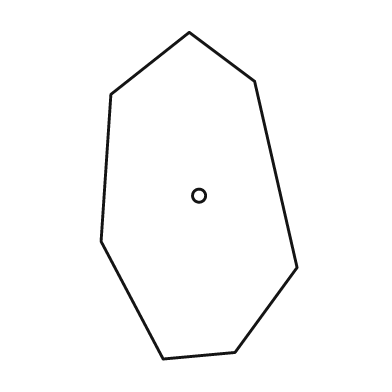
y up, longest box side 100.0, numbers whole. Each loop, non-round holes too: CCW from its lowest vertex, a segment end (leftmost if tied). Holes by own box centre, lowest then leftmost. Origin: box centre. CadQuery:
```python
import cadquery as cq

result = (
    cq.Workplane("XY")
    .moveTo(-11.0, -50.0)
    .lineTo(11.0, -48.0)
    .lineTo(30.0, -22.0)
    .lineTo(17.0, 35.0)
    .lineTo(-3.0, 50.0)
    .lineTo(-27.0, 31.0)
    .lineTo(-30.0, -14.0)
    .close()
    .moveTo(0.0, 0.0)
    .circle(2.0)
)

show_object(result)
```